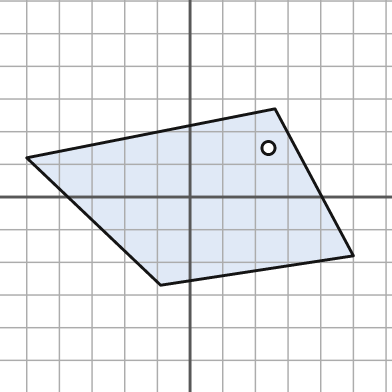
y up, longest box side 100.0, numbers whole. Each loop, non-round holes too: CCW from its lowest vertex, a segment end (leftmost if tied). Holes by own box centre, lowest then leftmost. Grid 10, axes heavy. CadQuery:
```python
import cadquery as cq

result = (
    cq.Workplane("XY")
    .moveTo(-9.0, -27.0)
    .lineTo(50.0, -18.0)
    .lineTo(26.0, 27.0)
    .lineTo(-50.0, 12.0)
    .close()
    .moveTo(24.0, 15.0)
    .circle(2.0)
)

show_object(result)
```